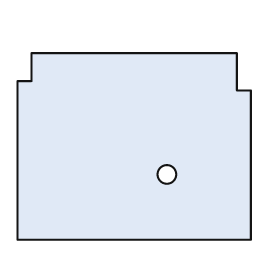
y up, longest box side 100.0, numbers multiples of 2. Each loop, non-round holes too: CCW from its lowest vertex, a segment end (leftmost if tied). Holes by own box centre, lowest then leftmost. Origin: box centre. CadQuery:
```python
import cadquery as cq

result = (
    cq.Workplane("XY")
    .moveTo(-50.0, -40.0)
    .lineTo(50.0, -40.0)
    .lineTo(50.0, 24.0)
    .lineTo(44.0, 24.0)
    .lineTo(44.0, 40.0)
    .lineTo(-44.0, 40.0)
    .lineTo(-44.0, 28.0)
    .lineTo(-50.0, 28.0)
    .close()
    .moveTo(14.0, -12.0)
    .circle(4.0)
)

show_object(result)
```